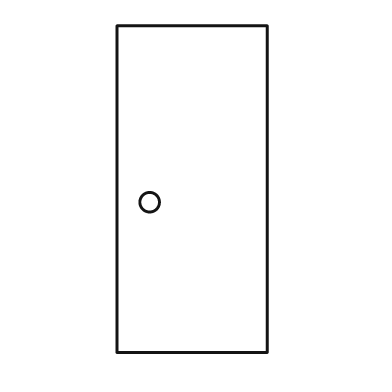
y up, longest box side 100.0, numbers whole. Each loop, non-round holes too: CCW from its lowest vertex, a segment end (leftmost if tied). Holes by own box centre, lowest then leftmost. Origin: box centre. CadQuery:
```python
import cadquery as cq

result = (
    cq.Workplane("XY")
    .moveTo(-23.0, -50.0)
    .lineTo(23.0, -50.0)
    .lineTo(23.0, 50.0)
    .lineTo(-23.0, 50.0)
    .close()
    .moveTo(-13.0, -4.0)
    .circle(3.0)
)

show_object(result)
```